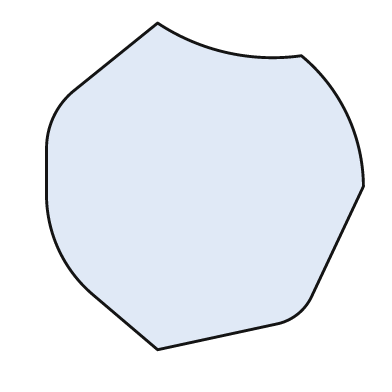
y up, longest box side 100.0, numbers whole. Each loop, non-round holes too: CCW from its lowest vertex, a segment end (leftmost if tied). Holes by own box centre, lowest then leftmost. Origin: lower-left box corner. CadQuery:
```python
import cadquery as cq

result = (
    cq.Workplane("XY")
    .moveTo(34.0, 0.0)
    .lineTo(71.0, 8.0)
    .threePointArc((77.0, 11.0), (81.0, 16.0))
    .lineTo(97.0, 50.0)
    .threePointArc((92.0, 72.0), (78.0, 90.0))
    .threePointArc((55.0, 91.0), (34.0, 100.0))
    .lineTo(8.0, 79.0)
    .threePointArc((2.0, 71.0), (0.0, 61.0))
    .lineTo(0.0, 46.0)
    .threePointArc((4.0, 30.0), (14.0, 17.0))
    .close()
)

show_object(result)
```